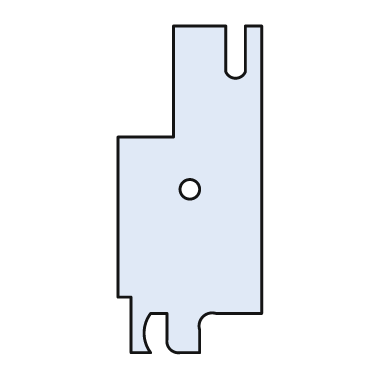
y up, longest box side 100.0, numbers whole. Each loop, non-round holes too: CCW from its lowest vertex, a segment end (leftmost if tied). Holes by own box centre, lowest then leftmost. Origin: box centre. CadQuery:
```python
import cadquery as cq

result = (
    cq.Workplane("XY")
    .moveTo(-18.0, -50.0)
    .lineTo(-12.0, -50.0)
    .threePointArc((-14.0, -44.0), (-12.0, -38.0))
    .lineTo(-7.0, -38.0)
    .lineTo(-7.0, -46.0)
    .threePointArc((-6.0, -49.0), (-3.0, -50.0))
    .lineTo(3.0, -50.0)
    .lineTo(3.0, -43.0)
    .threePointArc((4.0, -39.0), (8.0, -38.0))
    .lineTo(22.0, -38.0)
    .lineTo(22.0, 50.0)
    .lineTo(17.0, 50.0)
    .lineTo(17.0, 36.0)
    .threePointArc((14.0, 34.0), (11.0, 36.0))
    .lineTo(11.0, 50.0)
    .lineTo(-5.0, 50.0)
    .lineTo(-5.0, 16.0)
    .lineTo(-22.0, 16.0)
    .lineTo(-22.0, -33.0)
    .lineTo(-18.0, -33.0)
    .close()
    .moveTo(0.0, 0.0)
    .circle(3.0)
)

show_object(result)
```